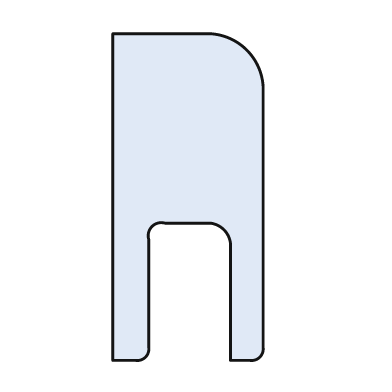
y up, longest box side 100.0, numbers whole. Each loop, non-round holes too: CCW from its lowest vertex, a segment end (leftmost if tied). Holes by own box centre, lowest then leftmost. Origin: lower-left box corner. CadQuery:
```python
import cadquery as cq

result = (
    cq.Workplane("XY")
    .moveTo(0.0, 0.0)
    .lineTo(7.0, 0.0)
    .threePointArc((10.0, 1.0), (11.0, 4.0))
    .lineTo(11.0, 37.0)
    .threePointArc((12.0, 41.0), (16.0, 42.0))
    .lineTo(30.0, 42.0)
    .threePointArc((34.0, 40.0), (36.0, 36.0))
    .lineTo(36.0, 0.0)
    .lineTo(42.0, 0.0)
    .threePointArc((45.0, 1.0), (46.0, 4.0))
    .lineTo(46.0, 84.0)
    .threePointArc((41.0, 95.0), (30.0, 100.0))
    .lineTo(0.0, 100.0)
    .close()
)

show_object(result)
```